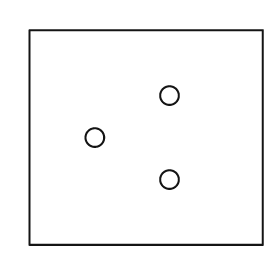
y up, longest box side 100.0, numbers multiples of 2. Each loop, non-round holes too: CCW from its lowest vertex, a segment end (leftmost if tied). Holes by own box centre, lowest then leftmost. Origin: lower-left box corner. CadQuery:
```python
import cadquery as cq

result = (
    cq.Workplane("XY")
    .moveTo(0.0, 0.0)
    .lineTo(100.0, 0.0)
    .lineTo(100.0, 92.0)
    .lineTo(0.0, 92.0)
    .close()
    .moveTo(60.0, 28.0)
    .circle(4.0)
    .moveTo(28.0, 46.0)
    .circle(4.0)
    .moveTo(60.0, 64.0)
    .circle(4.0)
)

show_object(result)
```